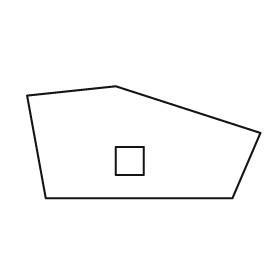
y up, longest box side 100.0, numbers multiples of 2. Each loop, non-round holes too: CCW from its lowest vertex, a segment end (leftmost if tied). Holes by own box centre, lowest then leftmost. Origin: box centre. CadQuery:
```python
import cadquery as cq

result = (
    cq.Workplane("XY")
    .moveTo(-42.0, -24.0)
    .lineTo(38.0, -24.0)
    .lineTo(50.0, 4.0)
    .lineTo(-12.0, 24.0)
    .lineTo(-50.0, 20.0)
    .close()
    .moveTo(-12.0, -14.0)
    .lineTo(0.0, -14.0)
    .lineTo(0.0, -2.0)
    .lineTo(-12.0, -2.0)
    .close()
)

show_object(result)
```